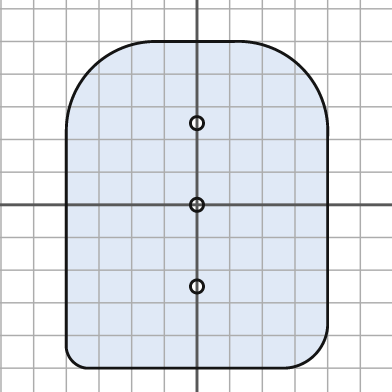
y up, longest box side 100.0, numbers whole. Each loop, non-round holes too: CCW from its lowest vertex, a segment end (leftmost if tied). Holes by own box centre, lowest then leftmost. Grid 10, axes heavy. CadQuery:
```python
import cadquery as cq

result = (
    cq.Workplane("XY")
    .moveTo(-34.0, -50.0)
    .lineTo(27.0, -50.0)
    .threePointArc((36.0, -46.0), (40.0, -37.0))
    .lineTo(40.0, 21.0)
    .threePointArc((32.0, 42.0), (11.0, 50.0))
    .lineTo(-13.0, 50.0)
    .threePointArc((-32.0, 42.0), (-40.0, 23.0))
    .lineTo(-40.0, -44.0)
    .threePointArc((-38.0, -48.0), (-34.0, -50.0))
    .close()
    .moveTo(0.0, -25.0)
    .circle(2.0)
    .moveTo(0.0, 0.0)
    .circle(2.0)
    .moveTo(0.0, 25.0)
    .circle(2.0)
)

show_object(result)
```